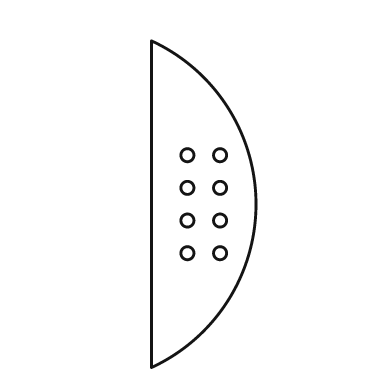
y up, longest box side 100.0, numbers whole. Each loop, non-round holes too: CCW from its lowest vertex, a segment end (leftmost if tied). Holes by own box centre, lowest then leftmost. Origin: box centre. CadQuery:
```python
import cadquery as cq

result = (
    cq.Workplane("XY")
    .moveTo(-16.0, -50.0)
    .threePointArc((16.0, 0.0), (-16.0, 50.0))
    .close()
    .moveTo(-5.0, -15.0)
    .circle(2.0)
    .moveTo(5.0, -15.0)
    .circle(2.0)
    .moveTo(-5.0, -5.0)
    .circle(2.0)
    .moveTo(5.0, -5.0)
    .circle(2.0)
    .moveTo(-5.0, 5.0)
    .circle(2.0)
    .moveTo(5.0, 5.0)
    .circle(2.0)
    .moveTo(-5.0, 15.0)
    .circle(2.0)
    .moveTo(5.0, 15.0)
    .circle(2.0)
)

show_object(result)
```